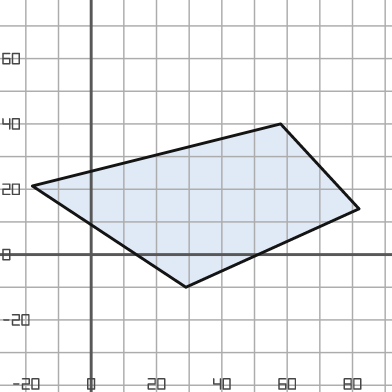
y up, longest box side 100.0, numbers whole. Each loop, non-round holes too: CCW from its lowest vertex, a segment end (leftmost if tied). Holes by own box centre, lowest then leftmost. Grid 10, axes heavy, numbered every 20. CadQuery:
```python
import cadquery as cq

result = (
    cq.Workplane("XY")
    .moveTo(29.0, -10.0)
    .lineTo(82.0, 14.0)
    .lineTo(58.0, 40.0)
    .lineTo(-18.0, 21.0)
    .close()
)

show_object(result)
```